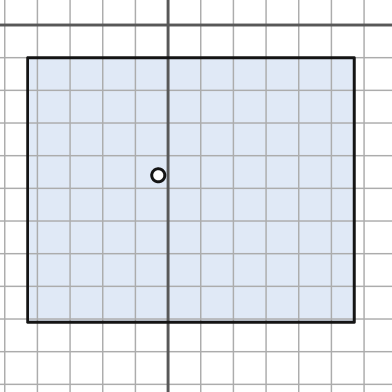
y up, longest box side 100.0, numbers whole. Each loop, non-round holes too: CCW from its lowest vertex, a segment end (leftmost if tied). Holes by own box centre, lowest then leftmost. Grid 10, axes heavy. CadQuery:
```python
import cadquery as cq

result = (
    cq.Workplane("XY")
    .moveTo(-43.0, -91.0)
    .lineTo(57.0, -91.0)
    .lineTo(57.0, -10.0)
    .lineTo(-43.0, -10.0)
    .close()
    .moveTo(-3.0, -46.0)
    .circle(2.0)
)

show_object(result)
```